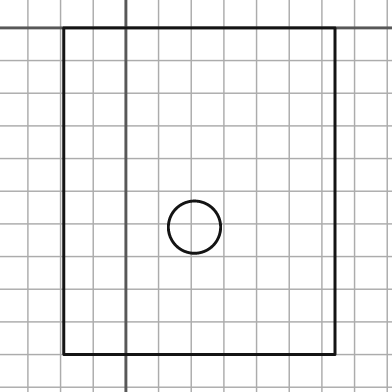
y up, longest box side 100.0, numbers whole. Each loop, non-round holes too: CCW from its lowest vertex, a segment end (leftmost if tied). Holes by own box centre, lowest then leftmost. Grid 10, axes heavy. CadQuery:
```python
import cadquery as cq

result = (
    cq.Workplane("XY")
    .moveTo(-19.0, -100.0)
    .lineTo(64.0, -100.0)
    .lineTo(64.0, 0.0)
    .lineTo(-19.0, 0.0)
    .close()
    .moveTo(21.0, -61.0)
    .circle(8.0)
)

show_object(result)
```